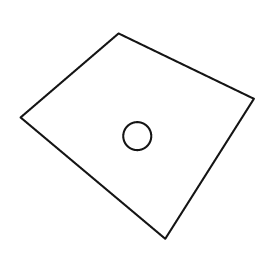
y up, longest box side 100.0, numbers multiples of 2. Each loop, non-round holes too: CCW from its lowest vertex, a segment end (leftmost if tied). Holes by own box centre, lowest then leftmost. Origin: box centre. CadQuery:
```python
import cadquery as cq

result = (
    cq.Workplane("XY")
    .moveTo(12.0, -44.0)
    .lineTo(50.0, 16.0)
    .lineTo(-8.0, 44.0)
    .lineTo(-50.0, 8.0)
    .close()
    .moveTo(0.0, 0.0)
    .circle(6.0)
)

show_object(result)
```